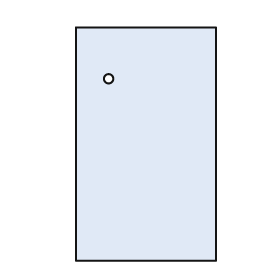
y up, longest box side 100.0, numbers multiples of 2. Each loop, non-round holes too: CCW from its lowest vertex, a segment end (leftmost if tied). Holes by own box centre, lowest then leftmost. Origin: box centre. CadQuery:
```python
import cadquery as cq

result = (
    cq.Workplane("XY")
    .moveTo(-30.0, -50.0)
    .lineTo(30.0, -50.0)
    .lineTo(30.0, 50.0)
    .lineTo(-30.0, 50.0)
    .close()
    .moveTo(-16.0, 28.0)
    .circle(2.0)
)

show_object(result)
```